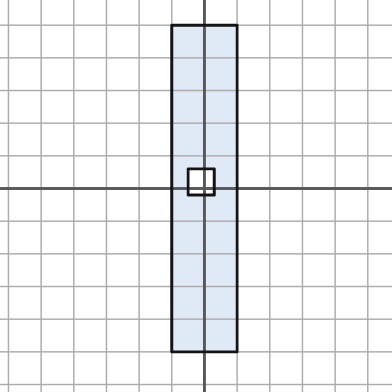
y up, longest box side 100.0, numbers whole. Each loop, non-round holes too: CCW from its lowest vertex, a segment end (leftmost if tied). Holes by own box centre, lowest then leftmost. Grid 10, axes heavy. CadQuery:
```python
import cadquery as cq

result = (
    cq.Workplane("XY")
    .moveTo(-10.0, -50.0)
    .lineTo(10.0, -50.0)
    .lineTo(10.0, 50.0)
    .lineTo(-10.0, 50.0)
    .close()
    .moveTo(-5.0, -2.0)
    .lineTo(3.0, -2.0)
    .lineTo(3.0, 6.0)
    .lineTo(-5.0, 6.0)
    .close()
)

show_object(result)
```